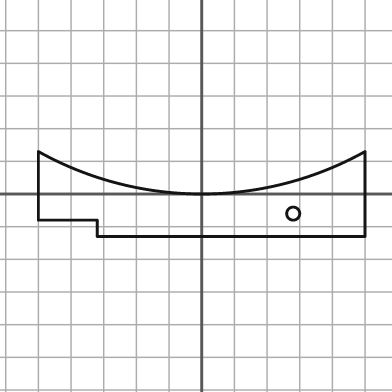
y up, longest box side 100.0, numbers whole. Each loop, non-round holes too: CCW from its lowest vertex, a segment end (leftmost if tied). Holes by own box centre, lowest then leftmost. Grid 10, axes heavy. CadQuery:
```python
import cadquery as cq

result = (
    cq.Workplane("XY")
    .moveTo(-32.0, -13.0)
    .lineTo(50.0, -13.0)
    .lineTo(50.0, 13.0)
    .threePointArc((0.0, 0.0), (-50.0, 13.0))
    .lineTo(-50.0, -8.0)
    .lineTo(-32.0, -8.0)
    .close()
    .moveTo(28.0, -6.0)
    .circle(2.0)
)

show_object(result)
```